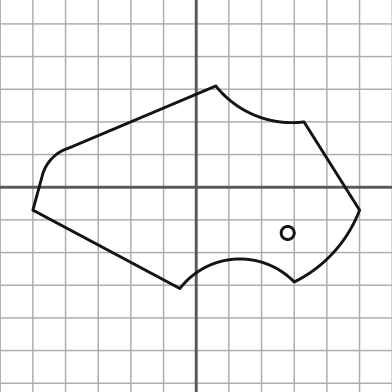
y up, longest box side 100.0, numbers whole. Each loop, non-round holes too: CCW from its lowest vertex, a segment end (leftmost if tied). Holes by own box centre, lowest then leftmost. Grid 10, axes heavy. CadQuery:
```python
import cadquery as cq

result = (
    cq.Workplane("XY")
    .moveTo(-5.0, -31.0)
    .threePointArc((12.0, -22.0), (30.0, -29.0))
    .threePointArc((42.0, -20.0), (50.0, -7.0))
    .lineTo(33.0, 20.0)
    .threePointArc((18.0, 22.0), (6.0, 31.0))
    .lineTo(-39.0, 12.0)
    .threePointArc((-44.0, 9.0), (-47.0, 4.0))
    .lineTo(-50.0, -7.0)
    .close()
    .moveTo(28.0, -14.0)
    .circle(2.0)
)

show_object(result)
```